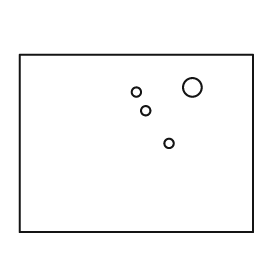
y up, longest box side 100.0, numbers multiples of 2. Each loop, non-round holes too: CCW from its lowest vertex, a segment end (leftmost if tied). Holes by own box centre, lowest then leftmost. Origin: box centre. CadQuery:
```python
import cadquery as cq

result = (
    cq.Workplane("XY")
    .moveTo(-50.0, -38.0)
    .lineTo(50.0, -38.0)
    .lineTo(50.0, 38.0)
    .lineTo(-50.0, 38.0)
    .close()
    .moveTo(14.0, 0.0)
    .circle(2.0)
    .moveTo(4.0, 14.0)
    .circle(2.0)
    .moveTo(0.0, 22.0)
    .circle(2.0)
    .moveTo(24.0, 24.0)
    .circle(4.0)
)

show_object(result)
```